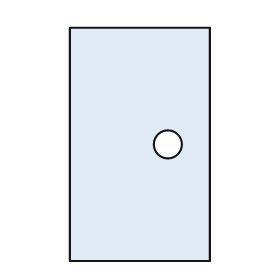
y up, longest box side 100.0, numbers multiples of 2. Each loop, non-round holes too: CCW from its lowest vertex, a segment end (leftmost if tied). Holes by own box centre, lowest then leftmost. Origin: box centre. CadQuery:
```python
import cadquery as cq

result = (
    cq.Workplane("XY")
    .moveTo(-30.0, -50.0)
    .lineTo(30.0, -50.0)
    .lineTo(30.0, 50.0)
    .lineTo(-30.0, 50.0)
    .close()
    .moveTo(12.0, 0.0)
    .circle(6.0)
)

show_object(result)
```